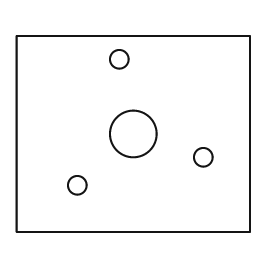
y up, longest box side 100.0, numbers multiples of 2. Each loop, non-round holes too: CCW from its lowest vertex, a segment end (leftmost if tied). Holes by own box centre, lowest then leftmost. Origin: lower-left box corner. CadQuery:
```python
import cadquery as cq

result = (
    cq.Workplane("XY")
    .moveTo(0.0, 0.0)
    .lineTo(100.0, 0.0)
    .lineTo(100.0, 84.0)
    .lineTo(0.0, 84.0)
    .close()
    .moveTo(26.0, 20.0)
    .circle(4.0)
    .moveTo(80.0, 32.0)
    .circle(4.0)
    .moveTo(50.0, 42.0)
    .circle(10.0)
    .moveTo(44.0, 74.0)
    .circle(4.0)
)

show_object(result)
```